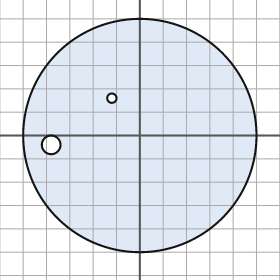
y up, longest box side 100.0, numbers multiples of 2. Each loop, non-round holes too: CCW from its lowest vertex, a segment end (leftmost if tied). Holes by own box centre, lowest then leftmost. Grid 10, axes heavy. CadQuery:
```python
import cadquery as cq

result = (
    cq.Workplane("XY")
    .moveTo(0.0, 0.0)
    .circle(50.0)
    .moveTo(-38.0, -4.0)
    .circle(4.0)
    .moveTo(-12.0, 16.0)
    .circle(2.0)
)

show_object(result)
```